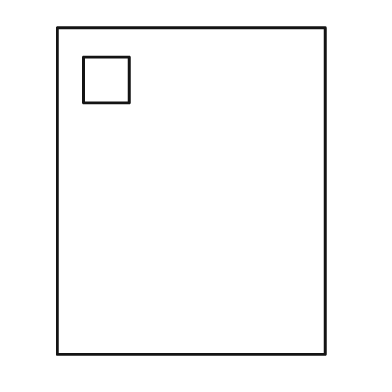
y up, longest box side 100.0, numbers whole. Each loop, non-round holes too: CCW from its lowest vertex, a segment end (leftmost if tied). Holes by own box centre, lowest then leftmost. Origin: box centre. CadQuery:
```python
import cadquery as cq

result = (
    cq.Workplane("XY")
    .moveTo(-41.0, -50.0)
    .lineTo(41.0, -50.0)
    .lineTo(41.0, 50.0)
    .lineTo(-41.0, 50.0)
    .close()
    .moveTo(-33.0, 27.0)
    .lineTo(-19.0, 27.0)
    .lineTo(-19.0, 41.0)
    .lineTo(-33.0, 41.0)
    .close()
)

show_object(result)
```